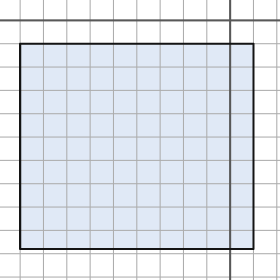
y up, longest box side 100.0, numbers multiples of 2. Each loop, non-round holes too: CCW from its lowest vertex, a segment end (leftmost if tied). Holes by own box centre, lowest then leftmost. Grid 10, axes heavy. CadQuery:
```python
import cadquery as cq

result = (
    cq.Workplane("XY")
    .moveTo(-90.0, -98.0)
    .lineTo(10.0, -98.0)
    .lineTo(10.0, -10.0)
    .lineTo(-90.0, -10.0)
    .close()
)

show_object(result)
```